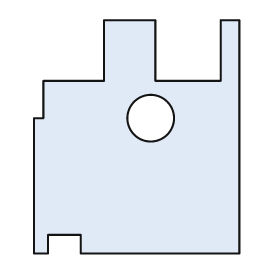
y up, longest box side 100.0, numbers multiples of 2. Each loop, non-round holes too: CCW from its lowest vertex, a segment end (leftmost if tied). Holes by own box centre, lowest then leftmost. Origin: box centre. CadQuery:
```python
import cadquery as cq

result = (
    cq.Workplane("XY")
    .moveTo(-44.0, -50.0)
    .lineTo(-38.0, -50.0)
    .lineTo(-38.0, -42.0)
    .lineTo(-24.0, -42.0)
    .lineTo(-24.0, -50.0)
    .lineTo(44.0, -50.0)
    .lineTo(44.0, 50.0)
    .lineTo(36.0, 50.0)
    .lineTo(36.0, 24.0)
    .lineTo(8.0, 24.0)
    .lineTo(8.0, 50.0)
    .lineTo(-14.0, 50.0)
    .lineTo(-14.0, 24.0)
    .lineTo(-40.0, 24.0)
    .lineTo(-40.0, 8.0)
    .lineTo(-44.0, 8.0)
    .close()
    .moveTo(6.0, 8.0)
    .circle(10.0)
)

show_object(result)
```